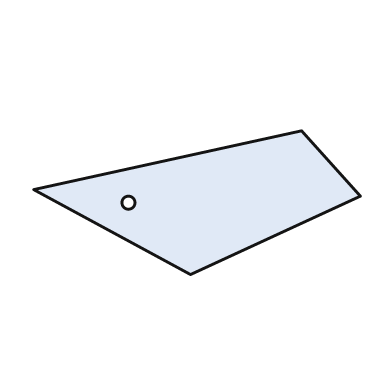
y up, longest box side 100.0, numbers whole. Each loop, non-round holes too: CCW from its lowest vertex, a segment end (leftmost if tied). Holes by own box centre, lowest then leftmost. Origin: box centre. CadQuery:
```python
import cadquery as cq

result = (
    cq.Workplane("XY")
    .moveTo(-2.0, -22.0)
    .lineTo(50.0, 2.0)
    .lineTo(32.0, 22.0)
    .lineTo(-50.0, 4.0)
    .close()
    .moveTo(-21.0, 0.0)
    .circle(2.0)
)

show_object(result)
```